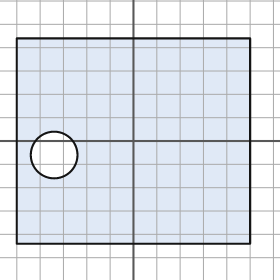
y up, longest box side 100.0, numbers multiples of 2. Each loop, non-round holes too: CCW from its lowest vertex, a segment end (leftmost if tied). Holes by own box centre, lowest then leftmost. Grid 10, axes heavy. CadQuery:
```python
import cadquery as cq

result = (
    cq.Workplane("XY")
    .moveTo(-50.0, -44.0)
    .lineTo(50.0, -44.0)
    .lineTo(50.0, 44.0)
    .lineTo(-50.0, 44.0)
    .close()
    .moveTo(-34.0, -6.0)
    .circle(10.0)
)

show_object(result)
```